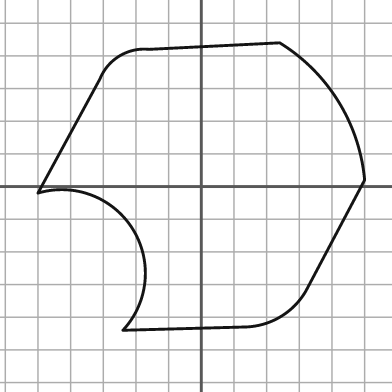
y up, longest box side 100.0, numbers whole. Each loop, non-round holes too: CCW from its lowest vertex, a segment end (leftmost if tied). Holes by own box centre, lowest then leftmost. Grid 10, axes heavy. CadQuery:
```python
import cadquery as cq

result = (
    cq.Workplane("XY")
    .moveTo(-24.0, -44.0)
    .lineTo(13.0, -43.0)
    .threePointArc((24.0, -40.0), (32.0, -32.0))
    .lineTo(50.0, 2.0)
    .threePointArc((42.0, 26.0), (24.0, 44.0))
    .lineTo(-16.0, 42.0)
    .threePointArc((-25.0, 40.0), (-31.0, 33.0))
    .lineTo(-50.0, -2.0)
    .threePointArc((-21.0, -13.0), (-24.0, -44.0))
    .close()
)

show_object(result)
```